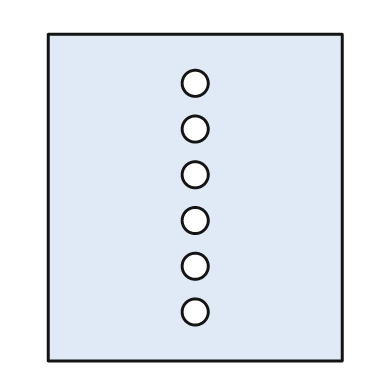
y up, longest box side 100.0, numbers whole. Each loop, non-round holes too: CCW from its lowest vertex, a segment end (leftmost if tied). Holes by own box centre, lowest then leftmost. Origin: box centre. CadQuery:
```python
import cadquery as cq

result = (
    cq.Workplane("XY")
    .moveTo(-45.0, -50.0)
    .lineTo(45.0, -50.0)
    .lineTo(45.0, 50.0)
    .lineTo(-45.0, 50.0)
    .close()
    .moveTo(0.0, -35.0)
    .circle(4.0)
    .moveTo(0.0, -21.0)
    .circle(4.0)
    .moveTo(0.0, -7.0)
    .circle(4.0)
    .moveTo(0.0, 7.0)
    .circle(4.0)
    .moveTo(0.0, 21.0)
    .circle(4.0)
    .moveTo(0.0, 35.0)
    .circle(4.0)
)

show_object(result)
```